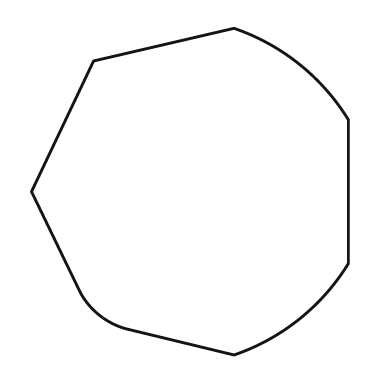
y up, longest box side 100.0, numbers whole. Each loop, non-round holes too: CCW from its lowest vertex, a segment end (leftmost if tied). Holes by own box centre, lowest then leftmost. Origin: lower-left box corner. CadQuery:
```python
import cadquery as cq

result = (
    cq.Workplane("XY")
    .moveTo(62.0, 0.0)
    .threePointArc((82.0, 11.0), (97.0, 28.0))
    .lineTo(97.0, 72.0)
    .threePointArc((82.0, 89.0), (62.0, 100.0))
    .lineTo(19.0, 90.0)
    .lineTo(0.0, 50.0)
    .lineTo(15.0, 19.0)
    .threePointArc((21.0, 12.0), (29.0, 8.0))
    .close()
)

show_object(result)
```